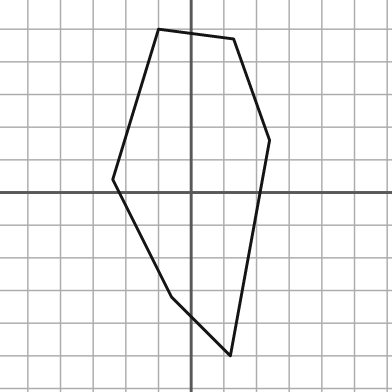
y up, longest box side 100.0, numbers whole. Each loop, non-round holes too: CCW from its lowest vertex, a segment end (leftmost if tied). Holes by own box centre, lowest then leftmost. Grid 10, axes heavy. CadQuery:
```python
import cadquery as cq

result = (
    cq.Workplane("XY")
    .moveTo(12.0, -50.0)
    .lineTo(24.0, 16.0)
    .lineTo(13.0, 47.0)
    .lineTo(-10.0, 50.0)
    .lineTo(-24.0, 4.0)
    .lineTo(-6.0, -32.0)
    .close()
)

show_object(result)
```